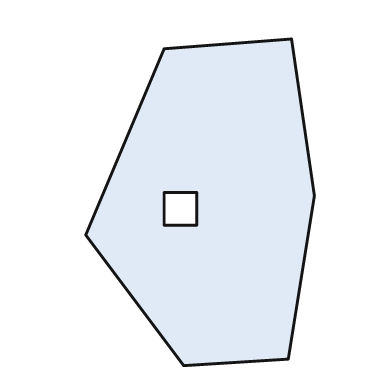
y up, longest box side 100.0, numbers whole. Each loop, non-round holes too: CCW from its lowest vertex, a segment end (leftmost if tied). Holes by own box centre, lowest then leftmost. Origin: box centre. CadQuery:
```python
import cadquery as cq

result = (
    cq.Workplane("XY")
    .moveTo(-5.0, -50.0)
    .lineTo(27.0, -48.0)
    .lineTo(35.0, 2.0)
    .lineTo(28.0, 50.0)
    .lineTo(-11.0, 47.0)
    .lineTo(-35.0, -10.0)
    .close()
    .moveTo(-11.0, -7.0)
    .lineTo(-1.0, -7.0)
    .lineTo(-1.0, 3.0)
    .lineTo(-11.0, 3.0)
    .close()
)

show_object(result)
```